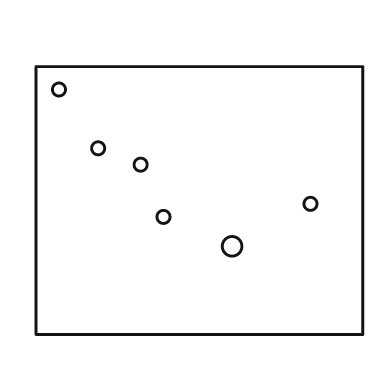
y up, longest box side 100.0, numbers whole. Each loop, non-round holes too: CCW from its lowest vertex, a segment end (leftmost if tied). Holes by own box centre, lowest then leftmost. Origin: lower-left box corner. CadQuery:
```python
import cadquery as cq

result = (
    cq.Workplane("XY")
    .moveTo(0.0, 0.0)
    .lineTo(100.0, 0.0)
    .lineTo(100.0, 82.0)
    .lineTo(0.0, 82.0)
    .close()
    .moveTo(60.0, 27.0)
    .circle(3.0)
    .moveTo(39.0, 36.0)
    .circle(2.0)
    .moveTo(84.0, 40.0)
    .circle(2.0)
    .moveTo(32.0, 52.0)
    .circle(2.0)
    .moveTo(19.0, 57.0)
    .circle(2.0)
    .moveTo(7.0, 75.0)
    .circle(2.0)
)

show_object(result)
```